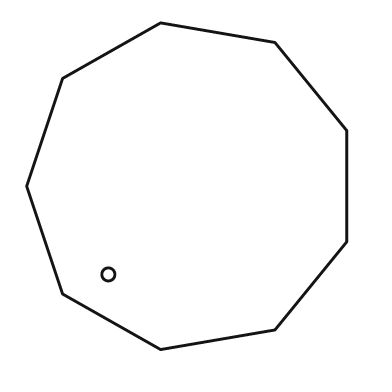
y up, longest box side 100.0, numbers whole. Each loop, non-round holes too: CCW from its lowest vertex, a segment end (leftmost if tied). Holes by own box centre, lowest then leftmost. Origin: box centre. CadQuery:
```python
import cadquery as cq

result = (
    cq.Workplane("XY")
    .moveTo(-8.0, -50.0)
    .lineTo(27.0, -44.0)
    .lineTo(49.0, -17.0)
    .lineTo(49.0, 17.0)
    .lineTo(27.0, 44.0)
    .lineTo(-8.0, 50.0)
    .lineTo(-38.0, 33.0)
    .lineTo(-49.0, 0.0)
    .lineTo(-38.0, -33.0)
    .close()
    .moveTo(-24.0, -27.0)
    .circle(2.0)
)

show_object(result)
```